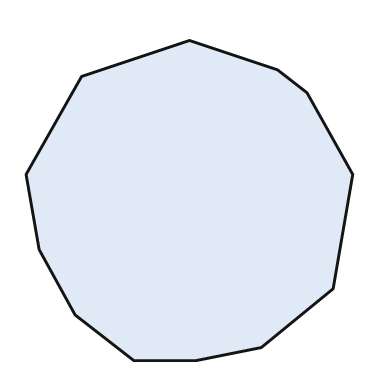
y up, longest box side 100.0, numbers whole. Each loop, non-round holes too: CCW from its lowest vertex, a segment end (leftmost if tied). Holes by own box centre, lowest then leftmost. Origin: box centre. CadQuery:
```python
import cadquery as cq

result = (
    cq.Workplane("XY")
    .moveTo(-17.0, -49.0)
    .lineTo(2.0, -49.0)
    .lineTo(22.0, -45.0)
    .lineTo(44.0, -27.0)
    .lineTo(50.0, 8.0)
    .lineTo(36.0, 33.0)
    .lineTo(27.0, 40.0)
    .lineTo(0.0, 49.0)
    .lineTo(-33.0, 38.0)
    .lineTo(-50.0, 8.0)
    .lineTo(-46.0, -15.0)
    .lineTo(-35.0, -35.0)
    .close()
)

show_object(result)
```